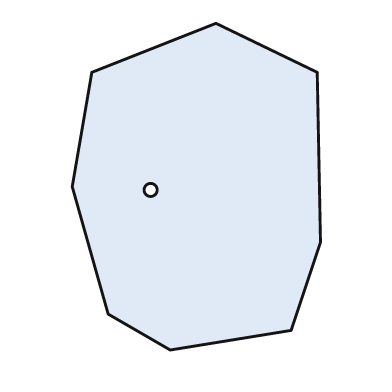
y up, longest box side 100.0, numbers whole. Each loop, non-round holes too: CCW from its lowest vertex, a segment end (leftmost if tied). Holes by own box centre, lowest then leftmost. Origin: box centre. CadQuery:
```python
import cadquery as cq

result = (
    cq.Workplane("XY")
    .moveTo(-8.0, -50.0)
    .lineTo(29.0, -44.0)
    .lineTo(38.0, -17.0)
    .lineTo(37.0, 35.0)
    .lineTo(6.0, 50.0)
    .lineTo(-32.0, 35.0)
    .lineTo(-38.0, 0.0)
    .lineTo(-27.0, -39.0)
    .close()
    .moveTo(-14.0, -1.0)
    .circle(2.0)
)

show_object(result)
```